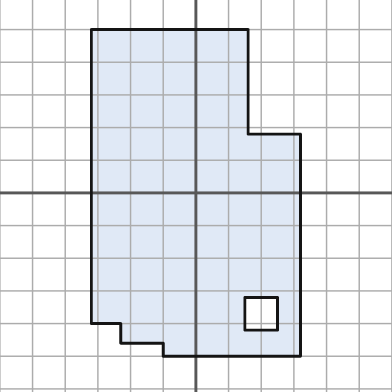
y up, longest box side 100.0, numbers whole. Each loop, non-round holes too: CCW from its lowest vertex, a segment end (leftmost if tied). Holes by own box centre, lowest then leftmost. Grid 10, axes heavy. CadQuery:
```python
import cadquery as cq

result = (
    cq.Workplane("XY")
    .moveTo(-10.0, -50.0)
    .lineTo(32.0, -50.0)
    .lineTo(32.0, 18.0)
    .lineTo(16.0, 18.0)
    .lineTo(16.0, 50.0)
    .lineTo(-32.0, 50.0)
    .lineTo(-32.0, -40.0)
    .lineTo(-23.0, -40.0)
    .lineTo(-23.0, -46.0)
    .lineTo(-10.0, -46.0)
    .close()
    .moveTo(15.0, -42.0)
    .lineTo(25.0, -42.0)
    .lineTo(25.0, -32.0)
    .lineTo(15.0, -32.0)
    .close()
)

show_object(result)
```